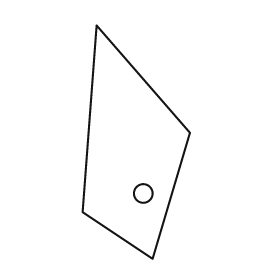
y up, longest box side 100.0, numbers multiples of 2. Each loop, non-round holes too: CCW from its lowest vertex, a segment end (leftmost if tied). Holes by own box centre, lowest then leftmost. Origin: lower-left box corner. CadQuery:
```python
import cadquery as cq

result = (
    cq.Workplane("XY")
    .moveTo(30.0, 0.0)
    .lineTo(46.0, 54.0)
    .lineTo(6.0, 100.0)
    .lineTo(0.0, 20.0)
    .close()
    .moveTo(26.0, 28.0)
    .circle(4.0)
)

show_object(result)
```